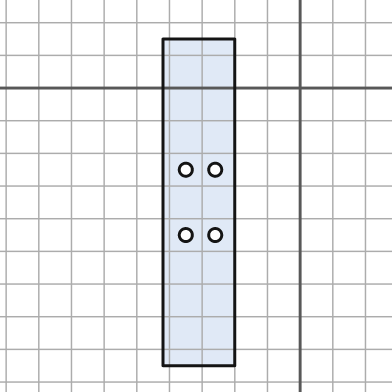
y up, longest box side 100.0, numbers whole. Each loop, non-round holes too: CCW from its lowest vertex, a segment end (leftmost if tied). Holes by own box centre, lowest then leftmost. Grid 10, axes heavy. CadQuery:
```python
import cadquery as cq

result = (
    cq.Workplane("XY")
    .moveTo(-42.0, -85.0)
    .lineTo(-20.0, -85.0)
    .lineTo(-20.0, 15.0)
    .lineTo(-42.0, 15.0)
    .close()
    .moveTo(-35.0, -45.0)
    .circle(2.0)
    .moveTo(-26.0, -45.0)
    .circle(2.0)
    .moveTo(-35.0, -25.0)
    .circle(2.0)
    .moveTo(-26.0, -25.0)
    .circle(2.0)
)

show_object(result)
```